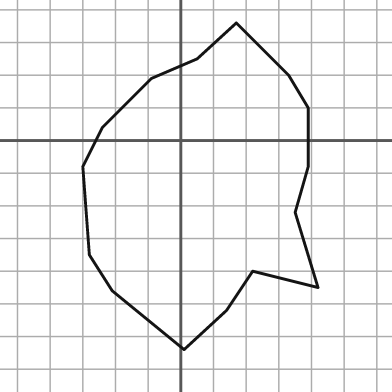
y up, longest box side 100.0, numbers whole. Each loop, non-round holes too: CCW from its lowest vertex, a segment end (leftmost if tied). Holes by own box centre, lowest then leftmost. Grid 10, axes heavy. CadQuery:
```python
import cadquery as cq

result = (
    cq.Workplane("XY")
    .moveTo(1.0, -64.0)
    .lineTo(14.0, -52.0)
    .lineTo(22.0, -40.0)
    .lineTo(42.0, -45.0)
    .lineTo(35.0, -22.0)
    .lineTo(39.0, -8.0)
    .lineTo(39.0, 10.0)
    .lineTo(33.0, 20.0)
    .lineTo(17.0, 36.0)
    .lineTo(5.0, 25.0)
    .lineTo(-9.0, 19.0)
    .lineTo(-24.0, 4.0)
    .lineTo(-30.0, -8.0)
    .lineTo(-28.0, -35.0)
    .lineTo(-21.0, -46.0)
    .close()
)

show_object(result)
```